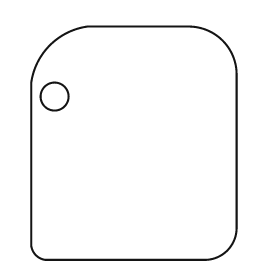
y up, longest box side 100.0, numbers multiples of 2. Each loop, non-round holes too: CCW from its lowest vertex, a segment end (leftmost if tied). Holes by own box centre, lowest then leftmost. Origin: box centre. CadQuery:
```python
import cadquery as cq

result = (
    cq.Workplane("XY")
    .moveTo(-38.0, -50.0)
    .lineTo(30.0, -50.0)
    .threePointArc((40.0, -46.0), (44.0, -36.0))
    .lineTo(44.0, 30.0)
    .threePointArc((38.0, 44.0), (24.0, 50.0))
    .lineTo(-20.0, 50.0)
    .threePointArc((-36.0, 42.0), (-44.0, 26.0))
    .lineTo(-44.0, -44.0)
    .threePointArc((-42.0, -48.0), (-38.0, -50.0))
    .close()
    .moveTo(-34.0, 20.0)
    .circle(6.0)
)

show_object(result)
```